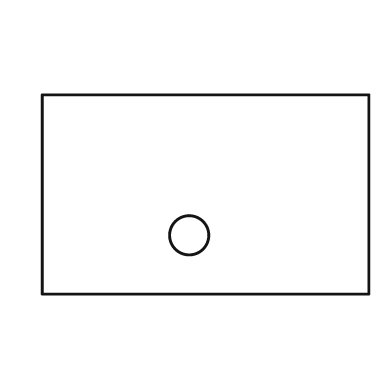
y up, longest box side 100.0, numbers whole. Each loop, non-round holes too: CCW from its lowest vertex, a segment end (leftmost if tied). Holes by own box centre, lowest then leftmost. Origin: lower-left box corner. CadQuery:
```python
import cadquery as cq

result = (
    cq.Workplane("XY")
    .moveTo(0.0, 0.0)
    .lineTo(100.0, 0.0)
    .lineTo(100.0, 61.0)
    .lineTo(0.0, 61.0)
    .close()
    .moveTo(45.0, 18.0)
    .circle(6.0)
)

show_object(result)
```